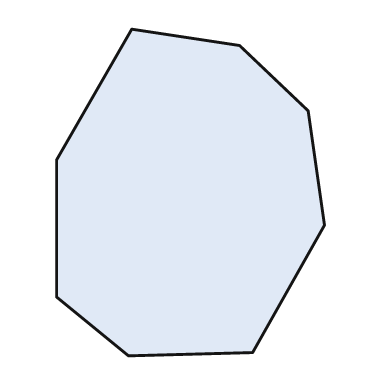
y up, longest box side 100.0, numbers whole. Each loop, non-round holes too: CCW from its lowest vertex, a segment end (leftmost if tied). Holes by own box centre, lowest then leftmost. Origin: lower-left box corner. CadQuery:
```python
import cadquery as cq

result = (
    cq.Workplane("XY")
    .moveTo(22.0, 0.0)
    .lineTo(60.0, 1.0)
    .lineTo(82.0, 40.0)
    .lineTo(77.0, 75.0)
    .lineTo(56.0, 95.0)
    .lineTo(23.0, 100.0)
    .lineTo(0.0, 60.0)
    .lineTo(0.0, 18.0)
    .close()
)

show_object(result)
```